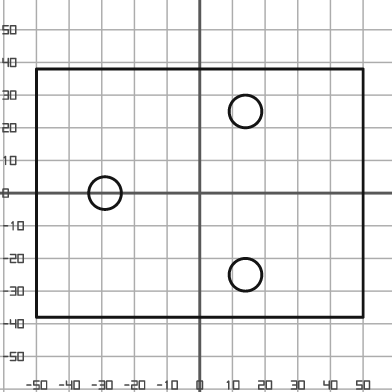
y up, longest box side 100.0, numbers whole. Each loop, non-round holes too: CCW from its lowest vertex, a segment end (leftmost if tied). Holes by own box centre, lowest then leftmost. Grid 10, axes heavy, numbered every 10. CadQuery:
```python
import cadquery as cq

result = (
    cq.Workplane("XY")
    .moveTo(-50.0, -38.0)
    .lineTo(50.0, -38.0)
    .lineTo(50.0, 38.0)
    .lineTo(-50.0, 38.0)
    .close()
    .moveTo(14.0, -25.0)
    .circle(5.0)
    .moveTo(-29.0, 0.0)
    .circle(5.0)
    .moveTo(14.0, 25.0)
    .circle(5.0)
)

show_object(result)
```